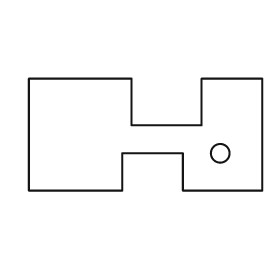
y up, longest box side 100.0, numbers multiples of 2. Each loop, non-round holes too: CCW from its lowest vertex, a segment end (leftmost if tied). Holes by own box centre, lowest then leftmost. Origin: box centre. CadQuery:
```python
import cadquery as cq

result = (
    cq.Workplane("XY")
    .moveTo(-50.0, -24.0)
    .lineTo(-10.0, -24.0)
    .lineTo(-10.0, -8.0)
    .lineTo(16.0, -8.0)
    .lineTo(16.0, -24.0)
    .lineTo(50.0, -24.0)
    .lineTo(50.0, 24.0)
    .lineTo(24.0, 24.0)
    .lineTo(24.0, 4.0)
    .lineTo(-6.0, 4.0)
    .lineTo(-6.0, 24.0)
    .lineTo(-50.0, 24.0)
    .close()
    .moveTo(32.0, -8.0)
    .circle(4.0)
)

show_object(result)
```